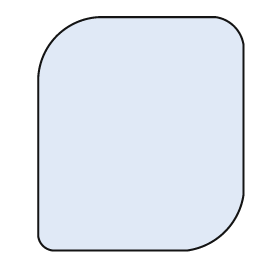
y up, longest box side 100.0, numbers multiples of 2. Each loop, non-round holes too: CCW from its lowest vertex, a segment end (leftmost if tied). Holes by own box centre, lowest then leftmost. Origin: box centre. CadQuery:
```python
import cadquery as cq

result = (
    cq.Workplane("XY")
    .moveTo(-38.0, -50.0)
    .lineTo(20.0, -50.0)
    .threePointArc((36.0, -42.0), (44.0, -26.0))
    .lineTo(44.0, 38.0)
    .threePointArc((40.0, 46.0), (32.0, 50.0))
    .lineTo(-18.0, 50.0)
    .threePointArc((-36.0, 42.0), (-44.0, 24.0))
    .lineTo(-44.0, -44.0)
    .threePointArc((-42.0, -48.0), (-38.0, -50.0))
    .close()
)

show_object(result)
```